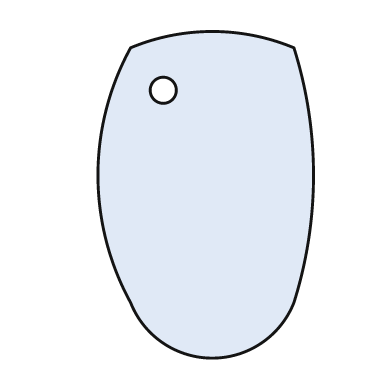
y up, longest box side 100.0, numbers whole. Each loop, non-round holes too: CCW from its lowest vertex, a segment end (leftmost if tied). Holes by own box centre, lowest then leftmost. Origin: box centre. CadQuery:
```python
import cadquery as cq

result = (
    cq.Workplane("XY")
    .moveTo(-23.0, -33.0)
    .threePointArc((2.0, -50.0), (27.0, -33.0))
    .threePointArc((33.0, 6.0), (27.0, 45.0))
    .threePointArc((2.0, 50.0), (-23.0, 45.0))
    .threePointArc((-33.0, 6.0), (-23.0, -33.0))
    .close()
    .moveTo(-13.0, 32.0)
    .circle(4.0)
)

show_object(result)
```